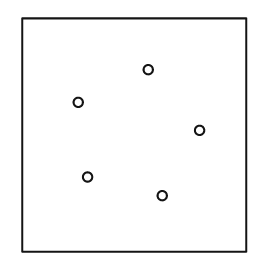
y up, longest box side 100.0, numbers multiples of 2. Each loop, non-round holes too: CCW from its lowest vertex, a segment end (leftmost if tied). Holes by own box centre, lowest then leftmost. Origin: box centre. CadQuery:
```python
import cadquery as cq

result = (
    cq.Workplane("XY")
    .moveTo(-48.0, -50.0)
    .lineTo(48.0, -50.0)
    .lineTo(48.0, 50.0)
    .lineTo(-48.0, 50.0)
    .close()
    .moveTo(12.0, -26.0)
    .circle(2.0)
    .moveTo(-20.0, -18.0)
    .circle(2.0)
    .moveTo(28.0, 2.0)
    .circle(2.0)
    .moveTo(-24.0, 14.0)
    .circle(2.0)
    .moveTo(6.0, 28.0)
    .circle(2.0)
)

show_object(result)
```